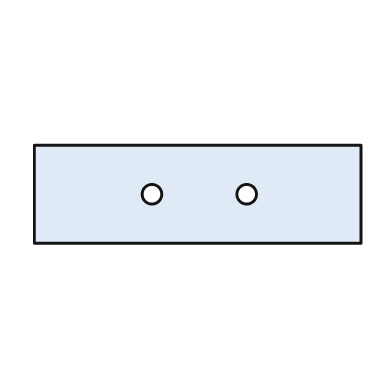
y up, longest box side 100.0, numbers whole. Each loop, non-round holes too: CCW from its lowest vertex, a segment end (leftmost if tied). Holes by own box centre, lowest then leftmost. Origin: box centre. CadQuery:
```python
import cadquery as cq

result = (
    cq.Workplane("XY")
    .moveTo(-50.0, -15.0)
    .lineTo(50.0, -15.0)
    .lineTo(50.0, 15.0)
    .lineTo(-50.0, 15.0)
    .close()
    .moveTo(-14.0, 0.0)
    .circle(3.0)
    .moveTo(15.0, 0.0)
    .circle(3.0)
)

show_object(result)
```